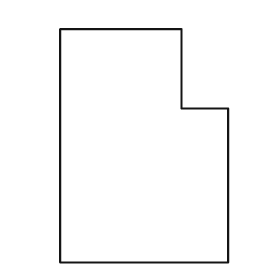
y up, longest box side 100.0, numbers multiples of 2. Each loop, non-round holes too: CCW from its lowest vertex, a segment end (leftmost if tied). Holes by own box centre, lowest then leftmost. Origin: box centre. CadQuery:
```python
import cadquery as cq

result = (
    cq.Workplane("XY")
    .moveTo(-36.0, -50.0)
    .lineTo(36.0, -50.0)
    .lineTo(36.0, 16.0)
    .lineTo(16.0, 16.0)
    .lineTo(16.0, 50.0)
    .lineTo(-36.0, 50.0)
    .close()
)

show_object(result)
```